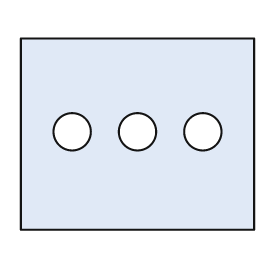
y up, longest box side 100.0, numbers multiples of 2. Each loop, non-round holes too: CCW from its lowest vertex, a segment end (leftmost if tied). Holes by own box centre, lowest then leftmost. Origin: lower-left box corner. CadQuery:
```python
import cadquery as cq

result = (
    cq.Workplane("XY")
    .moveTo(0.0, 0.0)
    .lineTo(100.0, 0.0)
    .lineTo(100.0, 82.0)
    .lineTo(0.0, 82.0)
    .close()
    .moveTo(22.0, 42.0)
    .circle(8.0)
    .moveTo(50.0, 42.0)
    .circle(8.0)
    .moveTo(78.0, 42.0)
    .circle(8.0)
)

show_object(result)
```